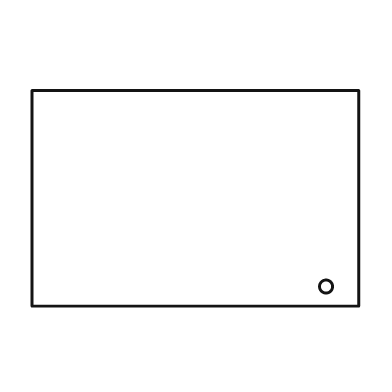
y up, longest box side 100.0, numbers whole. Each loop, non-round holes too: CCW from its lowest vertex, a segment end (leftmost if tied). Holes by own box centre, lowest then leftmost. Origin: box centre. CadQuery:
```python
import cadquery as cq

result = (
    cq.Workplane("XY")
    .moveTo(-50.0, -33.0)
    .lineTo(50.0, -33.0)
    .lineTo(50.0, 33.0)
    .lineTo(-50.0, 33.0)
    .close()
    .moveTo(40.0, -27.0)
    .circle(2.0)
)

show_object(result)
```